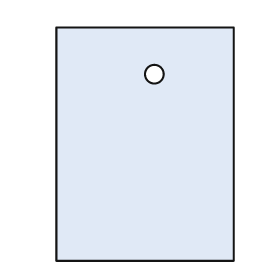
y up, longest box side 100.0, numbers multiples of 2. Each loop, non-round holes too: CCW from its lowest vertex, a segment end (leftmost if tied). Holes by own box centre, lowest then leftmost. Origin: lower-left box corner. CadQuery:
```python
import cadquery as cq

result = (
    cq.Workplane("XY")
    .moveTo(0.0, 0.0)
    .lineTo(76.0, 0.0)
    .lineTo(76.0, 100.0)
    .lineTo(0.0, 100.0)
    .close()
    .moveTo(42.0, 80.0)
    .circle(4.0)
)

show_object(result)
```